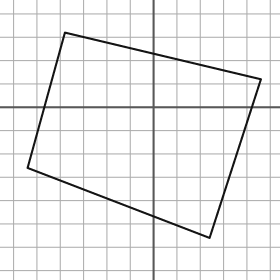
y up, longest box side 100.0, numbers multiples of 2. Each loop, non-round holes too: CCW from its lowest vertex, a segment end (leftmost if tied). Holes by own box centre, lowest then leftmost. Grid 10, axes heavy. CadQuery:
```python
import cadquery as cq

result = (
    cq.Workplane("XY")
    .moveTo(24.0, -56.0)
    .lineTo(46.0, 12.0)
    .lineTo(-38.0, 32.0)
    .lineTo(-54.0, -26.0)
    .close()
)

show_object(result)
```